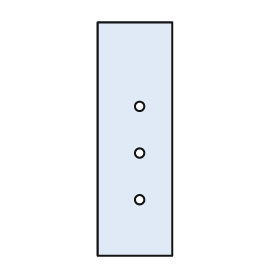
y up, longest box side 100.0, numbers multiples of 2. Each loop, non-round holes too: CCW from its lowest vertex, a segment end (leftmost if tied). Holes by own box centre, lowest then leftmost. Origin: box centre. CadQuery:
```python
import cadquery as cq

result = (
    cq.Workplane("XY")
    .moveTo(-16.0, -50.0)
    .lineTo(16.0, -50.0)
    .lineTo(16.0, 50.0)
    .lineTo(-16.0, 50.0)
    .close()
    .moveTo(2.0, -26.0)
    .circle(2.0)
    .moveTo(2.0, -6.0)
    .circle(2.0)
    .moveTo(2.0, 14.0)
    .circle(2.0)
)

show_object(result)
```